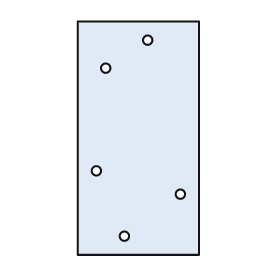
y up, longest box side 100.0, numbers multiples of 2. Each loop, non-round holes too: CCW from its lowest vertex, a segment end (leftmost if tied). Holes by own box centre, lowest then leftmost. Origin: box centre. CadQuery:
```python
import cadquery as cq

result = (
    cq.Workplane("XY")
    .moveTo(-26.0, -50.0)
    .lineTo(26.0, -50.0)
    .lineTo(26.0, 50.0)
    .lineTo(-26.0, 50.0)
    .close()
    .moveTo(-6.0, -42.0)
    .circle(2.0)
    .moveTo(18.0, -24.0)
    .circle(2.0)
    .moveTo(-18.0, -14.0)
    .circle(2.0)
    .moveTo(-14.0, 30.0)
    .circle(2.0)
    .moveTo(4.0, 42.0)
    .circle(2.0)
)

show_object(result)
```